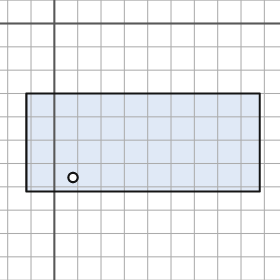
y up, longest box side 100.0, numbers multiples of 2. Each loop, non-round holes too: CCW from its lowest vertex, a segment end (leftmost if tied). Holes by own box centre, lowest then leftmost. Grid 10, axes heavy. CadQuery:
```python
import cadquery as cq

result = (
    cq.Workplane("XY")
    .moveTo(-12.0, -72.0)
    .lineTo(88.0, -72.0)
    .lineTo(88.0, -30.0)
    .lineTo(-12.0, -30.0)
    .close()
    .moveTo(8.0, -66.0)
    .circle(2.0)
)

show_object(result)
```